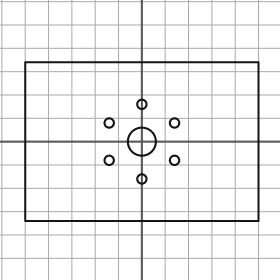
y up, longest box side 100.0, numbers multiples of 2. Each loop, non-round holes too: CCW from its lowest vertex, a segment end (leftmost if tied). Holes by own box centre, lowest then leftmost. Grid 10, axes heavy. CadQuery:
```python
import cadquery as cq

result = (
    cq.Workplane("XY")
    .moveTo(-50.0, -34.0)
    .lineTo(50.0, -34.0)
    .lineTo(50.0, 34.0)
    .lineTo(-50.0, 34.0)
    .close()
    .moveTo(0.0, -16.0)
    .circle(2.0)
    .moveTo(-14.0, -8.0)
    .circle(2.0)
    .moveTo(14.0, -8.0)
    .circle(2.0)
    .moveTo(0.0, 0.0)
    .circle(6.0)
    .moveTo(-14.0, 8.0)
    .circle(2.0)
    .moveTo(14.0, 8.0)
    .circle(2.0)
    .moveTo(0.0, 16.0)
    .circle(2.0)
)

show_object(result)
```